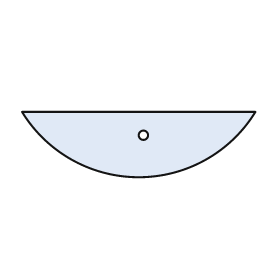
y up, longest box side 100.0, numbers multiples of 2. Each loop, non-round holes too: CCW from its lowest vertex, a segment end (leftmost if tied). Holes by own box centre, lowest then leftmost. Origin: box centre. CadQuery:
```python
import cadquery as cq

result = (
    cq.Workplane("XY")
    .moveTo(-50.0, 14.0)
    .threePointArc((0.0, -14.0), (50.0, 14.0))
    .close()
    .moveTo(2.0, 4.0)
    .circle(2.0)
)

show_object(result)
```